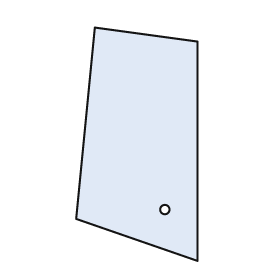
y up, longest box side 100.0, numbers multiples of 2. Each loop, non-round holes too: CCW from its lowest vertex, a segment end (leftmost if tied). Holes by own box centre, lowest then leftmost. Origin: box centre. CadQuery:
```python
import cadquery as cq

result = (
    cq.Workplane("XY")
    .moveTo(26.0, -50.0)
    .lineTo(26.0, 44.0)
    .lineTo(-18.0, 50.0)
    .lineTo(-26.0, -32.0)
    .close()
    .moveTo(12.0, -28.0)
    .circle(2.0)
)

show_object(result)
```